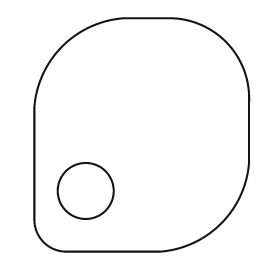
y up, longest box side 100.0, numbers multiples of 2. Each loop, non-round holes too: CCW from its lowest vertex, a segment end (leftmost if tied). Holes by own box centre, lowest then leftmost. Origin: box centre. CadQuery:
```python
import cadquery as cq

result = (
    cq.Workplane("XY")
    .moveTo(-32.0, -50.0)
    .lineTo(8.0, -50.0)
    .threePointArc((34.0, -38.0), (46.0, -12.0))
    .lineTo(46.0, 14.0)
    .threePointArc((36.0, 40.0), (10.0, 50.0))
    .lineTo(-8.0, 50.0)
    .threePointArc((-34.0, 38.0), (-46.0, 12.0))
    .lineTo(-46.0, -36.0)
    .threePointArc((-42.0, -46.0), (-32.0, -50.0))
    .close()
    .moveTo(-24.0, -24.0)
    .circle(12.0)
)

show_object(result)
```